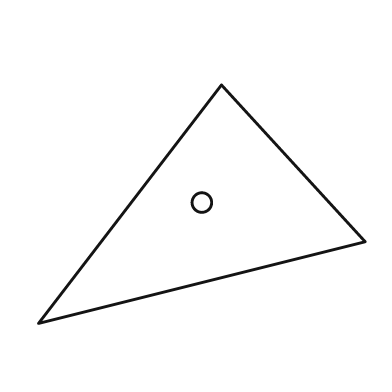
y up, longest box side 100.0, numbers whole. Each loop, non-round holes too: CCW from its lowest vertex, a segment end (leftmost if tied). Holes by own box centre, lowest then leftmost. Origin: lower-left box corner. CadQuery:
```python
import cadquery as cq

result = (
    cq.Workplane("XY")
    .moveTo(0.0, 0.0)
    .lineTo(100.0, 25.0)
    .lineTo(56.0, 73.0)
    .close()
    .moveTo(50.0, 37.0)
    .circle(3.0)
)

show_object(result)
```